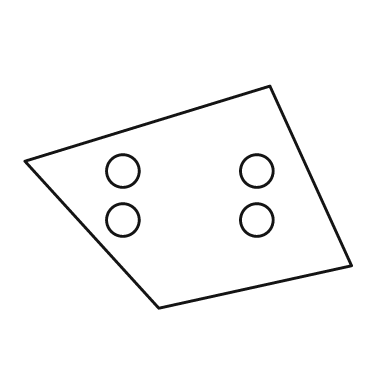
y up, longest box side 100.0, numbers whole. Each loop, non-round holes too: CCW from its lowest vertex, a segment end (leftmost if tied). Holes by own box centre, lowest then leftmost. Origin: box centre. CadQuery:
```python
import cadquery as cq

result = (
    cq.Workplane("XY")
    .moveTo(-9.0, -34.0)
    .lineTo(50.0, -21.0)
    .lineTo(25.0, 34.0)
    .lineTo(-50.0, 11.0)
    .close()
    .moveTo(-20.0, -7.0)
    .circle(5.0)
    .moveTo(21.0, -7.0)
    .circle(5.0)
    .moveTo(-20.0, 8.0)
    .circle(5.0)
    .moveTo(21.0, 8.0)
    .circle(5.0)
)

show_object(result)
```